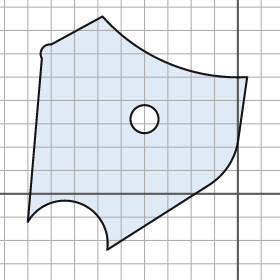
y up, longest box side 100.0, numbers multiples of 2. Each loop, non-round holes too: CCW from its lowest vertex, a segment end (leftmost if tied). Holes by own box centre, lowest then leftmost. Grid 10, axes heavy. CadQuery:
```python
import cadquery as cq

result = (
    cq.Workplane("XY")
    .moveTo(-56.0, -24.0)
    .lineTo(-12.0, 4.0)
    .threePointArc((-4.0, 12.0), (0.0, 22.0))
    .lineTo(4.0, 50.0)
    .threePointArc((-30.0, 56.0), (-58.0, 76.0))
    .lineTo(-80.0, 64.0)
    .threePointArc((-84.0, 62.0), (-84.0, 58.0))
    .lineTo(-90.0, -12.0)
    .threePointArc((-68.0, -4.0), (-56.0, -24.0))
    .close()
    .moveTo(-40.0, 32.0)
    .circle(6.0)
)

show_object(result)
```